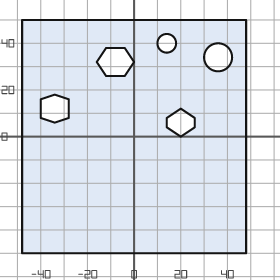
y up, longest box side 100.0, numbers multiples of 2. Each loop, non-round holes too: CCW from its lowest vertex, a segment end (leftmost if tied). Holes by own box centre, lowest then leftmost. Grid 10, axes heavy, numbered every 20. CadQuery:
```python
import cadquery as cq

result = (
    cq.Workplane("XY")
    .moveTo(-48.0, -50.0)
    .lineTo(48.0, -50.0)
    .lineTo(48.0, 50.0)
    .lineTo(-48.0, 50.0)
    .close()
    .moveTo(20.0, 0.0)
    .lineTo(26.0, 4.0)
    .lineTo(26.0, 8.0)
    .lineTo(20.0, 12.0)
    .lineTo(14.0, 8.0)
    .lineTo(14.0, 4.0)
    .close()
    .moveTo(-34.0, 6.0)
    .lineTo(-28.0, 8.0)
    .lineTo(-28.0, 16.0)
    .lineTo(-34.0, 18.0)
    .lineTo(-40.0, 16.0)
    .lineTo(-40.0, 8.0)
    .close()
    .moveTo(-12.0, 26.0)
    .lineTo(-4.0, 26.0)
    .lineTo(0.0, 32.0)
    .lineTo(-4.0, 38.0)
    .lineTo(-12.0, 38.0)
    .lineTo(-16.0, 32.0)
    .close()
    .moveTo(36.0, 34.0)
    .circle(6.0)
    .moveTo(14.0, 40.0)
    .circle(4.0)
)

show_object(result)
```